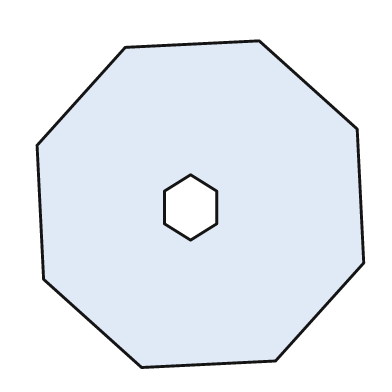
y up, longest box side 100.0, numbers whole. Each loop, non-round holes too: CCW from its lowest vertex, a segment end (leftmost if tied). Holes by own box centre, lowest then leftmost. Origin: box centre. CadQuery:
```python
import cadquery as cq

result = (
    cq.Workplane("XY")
    .moveTo(-18.0, -50.0)
    .lineTo(23.0, -48.0)
    .lineTo(50.0, -18.0)
    .lineTo(48.0, 23.0)
    .lineTo(18.0, 50.0)
    .lineTo(-23.0, 48.0)
    .lineTo(-50.0, 18.0)
    .lineTo(-48.0, -23.0)
    .close()
    .moveTo(-3.0, -11.0)
    .lineTo(5.0, -6.0)
    .lineTo(5.0, 4.0)
    .lineTo(-3.0, 9.0)
    .lineTo(-11.0, 4.0)
    .lineTo(-11.0, -6.0)
    .close()
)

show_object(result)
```